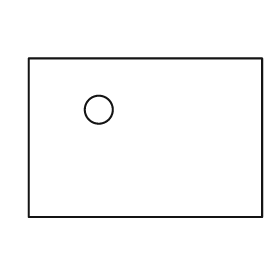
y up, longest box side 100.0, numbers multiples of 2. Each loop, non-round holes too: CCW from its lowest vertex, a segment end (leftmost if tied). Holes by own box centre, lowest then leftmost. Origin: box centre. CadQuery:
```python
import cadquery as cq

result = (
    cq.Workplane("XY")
    .moveTo(-50.0, -34.0)
    .lineTo(50.0, -34.0)
    .lineTo(50.0, 34.0)
    .lineTo(-50.0, 34.0)
    .close()
    .moveTo(-20.0, 12.0)
    .circle(6.0)
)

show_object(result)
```